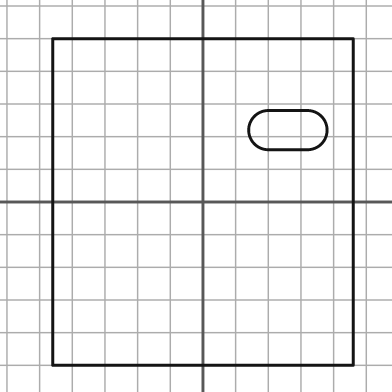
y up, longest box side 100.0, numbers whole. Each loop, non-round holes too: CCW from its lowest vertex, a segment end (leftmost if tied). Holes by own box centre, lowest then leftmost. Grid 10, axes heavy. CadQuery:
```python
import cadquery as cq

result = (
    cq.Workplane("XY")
    .moveTo(-46.0, -50.0)
    .lineTo(46.0, -50.0)
    .lineTo(46.0, 50.0)
    .lineTo(-46.0, 50.0)
    .close()
    .moveTo(20.0, 16.0)
    .lineTo(32.0, 16.0)
    .threePointArc((38.0, 22.0), (32.0, 28.0))
    .lineTo(20.0, 28.0)
    .threePointArc((14.0, 22.0), (20.0, 16.0))
    .close()
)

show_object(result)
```